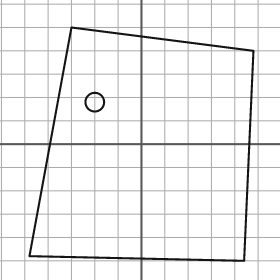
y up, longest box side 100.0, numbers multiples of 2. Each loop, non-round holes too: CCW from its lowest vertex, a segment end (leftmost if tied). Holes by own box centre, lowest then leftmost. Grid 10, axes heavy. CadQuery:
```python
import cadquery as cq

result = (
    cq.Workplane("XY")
    .moveTo(44.0, -50.0)
    .lineTo(48.0, 40.0)
    .lineTo(-30.0, 50.0)
    .lineTo(-48.0, -48.0)
    .close()
    .moveTo(-20.0, 18.0)
    .circle(4.0)
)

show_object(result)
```